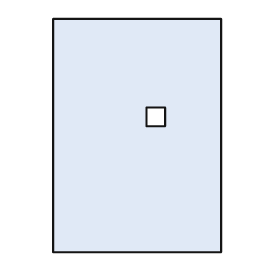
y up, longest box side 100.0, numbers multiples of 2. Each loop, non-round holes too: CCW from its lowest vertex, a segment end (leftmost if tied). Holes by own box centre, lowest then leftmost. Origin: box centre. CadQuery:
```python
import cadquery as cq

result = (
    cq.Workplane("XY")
    .moveTo(-36.0, -50.0)
    .lineTo(36.0, -50.0)
    .lineTo(36.0, 50.0)
    .lineTo(-36.0, 50.0)
    .close()
    .moveTo(4.0, 4.0)
    .lineTo(12.0, 4.0)
    .lineTo(12.0, 12.0)
    .lineTo(4.0, 12.0)
    .close()
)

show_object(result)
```